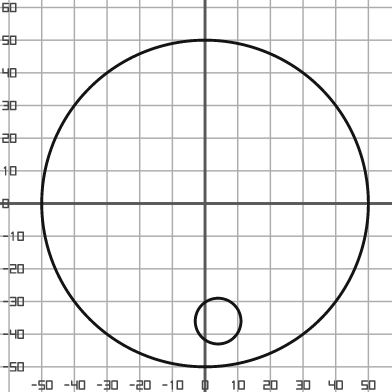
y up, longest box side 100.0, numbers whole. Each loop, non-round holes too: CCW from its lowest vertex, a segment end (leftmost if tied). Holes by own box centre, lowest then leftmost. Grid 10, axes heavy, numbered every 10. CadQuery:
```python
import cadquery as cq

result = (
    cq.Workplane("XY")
    .moveTo(0.0, 0.0)
    .circle(50.0)
    .moveTo(4.0, -36.0)
    .circle(7.0)
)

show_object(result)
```